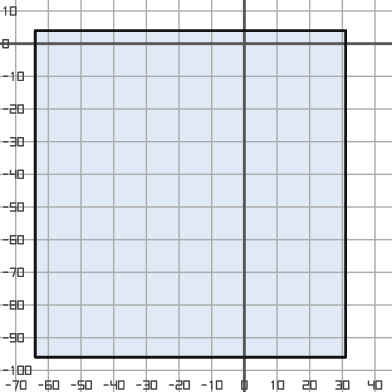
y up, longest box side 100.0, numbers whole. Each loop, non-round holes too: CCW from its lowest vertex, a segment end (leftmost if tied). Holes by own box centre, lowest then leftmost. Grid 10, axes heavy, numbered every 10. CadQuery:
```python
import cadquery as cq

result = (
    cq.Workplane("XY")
    .moveTo(-64.0, -96.0)
    .lineTo(31.0, -96.0)
    .lineTo(31.0, 4.0)
    .lineTo(-64.0, 4.0)
    .close()
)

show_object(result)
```